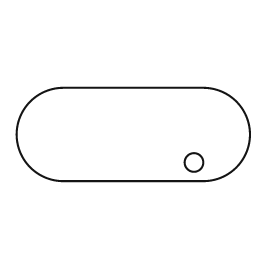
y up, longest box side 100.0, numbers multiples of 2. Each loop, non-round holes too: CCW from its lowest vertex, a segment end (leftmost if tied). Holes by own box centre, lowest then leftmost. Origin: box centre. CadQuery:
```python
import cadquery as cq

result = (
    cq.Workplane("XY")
    .moveTo(-30.0, -20.0)
    .lineTo(30.0, -20.0)
    .threePointArc((50.0, 0.0), (30.0, 20.0))
    .lineTo(-30.0, 20.0)
    .threePointArc((-50.0, 0.0), (-30.0, -20.0))
    .close()
    .moveTo(26.0, -12.0)
    .circle(4.0)
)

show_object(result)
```